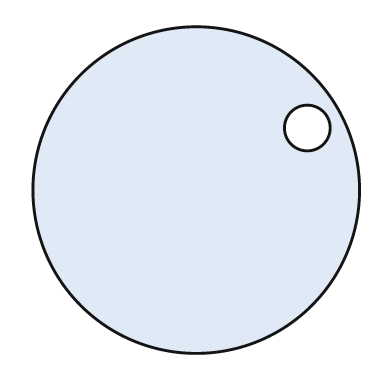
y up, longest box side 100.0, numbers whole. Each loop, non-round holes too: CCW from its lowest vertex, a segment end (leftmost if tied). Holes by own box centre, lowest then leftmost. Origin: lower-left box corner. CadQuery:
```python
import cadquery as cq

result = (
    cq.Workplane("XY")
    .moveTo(50.0, 50.0)
    .circle(50.0)
    .moveTo(84.0, 69.0)
    .circle(7.0)
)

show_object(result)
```